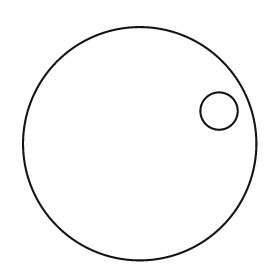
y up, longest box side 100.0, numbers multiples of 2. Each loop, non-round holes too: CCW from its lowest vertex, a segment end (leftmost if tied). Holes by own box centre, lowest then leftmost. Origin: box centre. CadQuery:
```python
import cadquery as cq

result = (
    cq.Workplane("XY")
    .moveTo(0.0, 0.0)
    .circle(50.0)
    .moveTo(34.0, 14.0)
    .circle(8.0)
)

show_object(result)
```